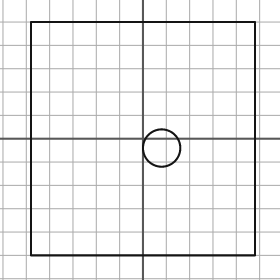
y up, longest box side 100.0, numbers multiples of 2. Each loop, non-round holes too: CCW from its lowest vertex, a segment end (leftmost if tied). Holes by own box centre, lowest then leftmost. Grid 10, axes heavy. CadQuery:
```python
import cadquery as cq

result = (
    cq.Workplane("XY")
    .moveTo(-48.0, -50.0)
    .lineTo(48.0, -50.0)
    .lineTo(48.0, 50.0)
    .lineTo(-48.0, 50.0)
    .close()
    .moveTo(8.0, -4.0)
    .circle(8.0)
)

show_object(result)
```